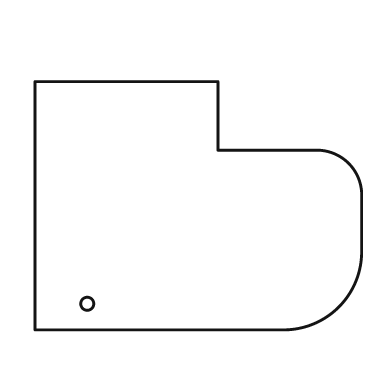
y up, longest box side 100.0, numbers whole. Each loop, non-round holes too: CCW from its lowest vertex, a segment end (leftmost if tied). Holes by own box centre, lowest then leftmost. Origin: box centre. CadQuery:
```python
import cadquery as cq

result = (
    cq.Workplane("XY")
    .moveTo(-50.0, -38.0)
    .lineTo(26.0, -38.0)
    .threePointArc((43.0, -31.0), (50.0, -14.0))
    .lineTo(50.0, 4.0)
    .threePointArc((46.0, 13.0), (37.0, 17.0))
    .lineTo(6.0, 17.0)
    .lineTo(6.0, 38.0)
    .lineTo(-50.0, 38.0)
    .close()
    .moveTo(-34.0, -30.0)
    .circle(2.0)
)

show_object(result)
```